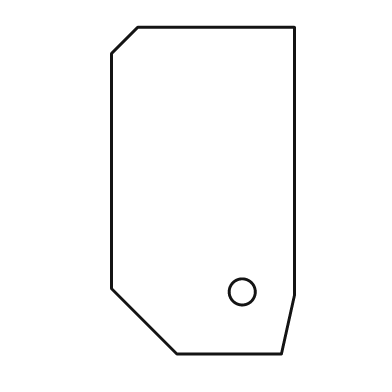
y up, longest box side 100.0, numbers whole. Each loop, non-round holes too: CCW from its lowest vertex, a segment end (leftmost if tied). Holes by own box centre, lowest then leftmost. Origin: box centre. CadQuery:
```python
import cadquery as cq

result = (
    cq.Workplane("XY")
    .moveTo(-8.0, -50.0)
    .lineTo(24.0, -50.0)
    .lineTo(28.0, -32.0)
    .lineTo(28.0, 50.0)
    .lineTo(-20.0, 50.0)
    .lineTo(-28.0, 42.0)
    .lineTo(-28.0, -30.0)
    .close()
    .moveTo(12.0, -31.0)
    .circle(4.0)
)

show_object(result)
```